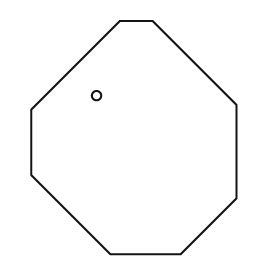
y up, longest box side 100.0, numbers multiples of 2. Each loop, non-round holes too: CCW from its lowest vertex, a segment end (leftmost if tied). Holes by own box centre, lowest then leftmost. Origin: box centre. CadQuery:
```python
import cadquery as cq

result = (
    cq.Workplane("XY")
    .moveTo(-10.0, -50.0)
    .lineTo(20.0, -50.0)
    .lineTo(44.0, -26.0)
    .lineTo(44.0, 14.0)
    .lineTo(8.0, 50.0)
    .lineTo(-6.0, 50.0)
    .lineTo(-44.0, 12.0)
    .lineTo(-44.0, -16.0)
    .close()
    .moveTo(-16.0, 18.0)
    .circle(2.0)
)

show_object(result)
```